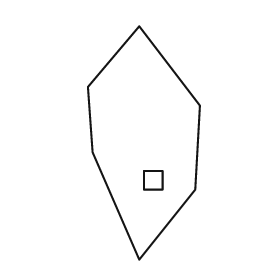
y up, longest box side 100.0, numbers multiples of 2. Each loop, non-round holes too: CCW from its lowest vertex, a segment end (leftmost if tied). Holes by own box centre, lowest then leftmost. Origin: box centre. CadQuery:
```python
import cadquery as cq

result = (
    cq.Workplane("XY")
    .moveTo(-2.0, -50.0)
    .lineTo(22.0, -20.0)
    .lineTo(24.0, 16.0)
    .lineTo(-2.0, 50.0)
    .lineTo(-24.0, 24.0)
    .lineTo(-22.0, -4.0)
    .close()
    .moveTo(0.0, -20.0)
    .lineTo(8.0, -20.0)
    .lineTo(8.0, -12.0)
    .lineTo(0.0, -12.0)
    .close()
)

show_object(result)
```